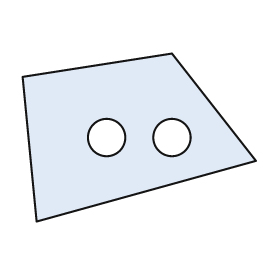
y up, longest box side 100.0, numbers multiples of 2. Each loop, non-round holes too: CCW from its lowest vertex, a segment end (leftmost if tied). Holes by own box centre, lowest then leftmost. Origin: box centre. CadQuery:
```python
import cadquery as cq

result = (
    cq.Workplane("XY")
    .moveTo(-44.0, -36.0)
    .lineTo(50.0, -10.0)
    .lineTo(14.0, 36.0)
    .lineTo(-50.0, 26.0)
    .close()
    .moveTo(-14.0, 0.0)
    .circle(8.0)
    .moveTo(14.0, 0.0)
    .circle(8.0)
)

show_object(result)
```